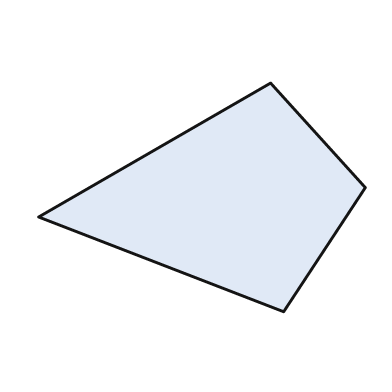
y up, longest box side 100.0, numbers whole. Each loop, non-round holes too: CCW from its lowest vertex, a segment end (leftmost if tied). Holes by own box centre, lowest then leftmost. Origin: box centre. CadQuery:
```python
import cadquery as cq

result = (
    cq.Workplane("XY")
    .moveTo(25.0, -35.0)
    .lineTo(50.0, 3.0)
    .lineTo(21.0, 35.0)
    .lineTo(-50.0, -6.0)
    .close()
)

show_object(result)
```